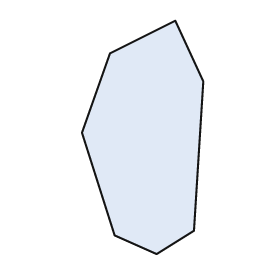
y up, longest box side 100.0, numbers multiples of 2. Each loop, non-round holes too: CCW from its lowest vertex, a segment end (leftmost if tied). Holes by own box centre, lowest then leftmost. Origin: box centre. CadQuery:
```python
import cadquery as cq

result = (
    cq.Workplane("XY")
    .moveTo(6.0, -50.0)
    .lineTo(22.0, -40.0)
    .lineTo(26.0, 24.0)
    .lineTo(14.0, 50.0)
    .lineTo(-14.0, 36.0)
    .lineTo(-26.0, 2.0)
    .lineTo(-12.0, -42.0)
    .close()
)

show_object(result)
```